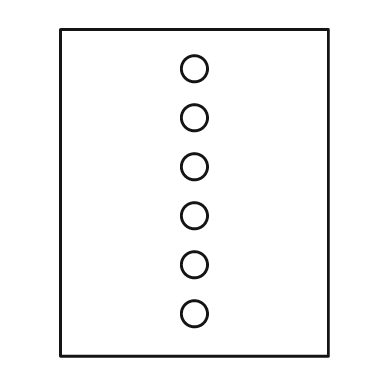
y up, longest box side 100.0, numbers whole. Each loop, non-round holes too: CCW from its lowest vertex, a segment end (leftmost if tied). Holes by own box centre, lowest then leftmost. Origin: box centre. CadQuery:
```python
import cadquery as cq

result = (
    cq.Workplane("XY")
    .moveTo(-41.0, -50.0)
    .lineTo(41.0, -50.0)
    .lineTo(41.0, 50.0)
    .lineTo(-41.0, 50.0)
    .close()
    .moveTo(0.0, -37.0)
    .circle(4.0)
    .moveTo(0.0, -22.0)
    .circle(4.0)
    .moveTo(0.0, -7.0)
    .circle(4.0)
    .moveTo(0.0, 8.0)
    .circle(4.0)
    .moveTo(0.0, 23.0)
    .circle(4.0)
    .moveTo(0.0, 38.0)
    .circle(4.0)
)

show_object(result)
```